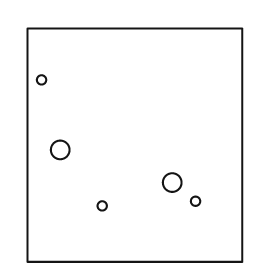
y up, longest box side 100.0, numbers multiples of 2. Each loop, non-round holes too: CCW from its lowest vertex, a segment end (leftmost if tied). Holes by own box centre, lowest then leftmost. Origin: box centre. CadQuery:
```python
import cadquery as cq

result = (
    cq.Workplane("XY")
    .moveTo(-46.0, -50.0)
    .lineTo(46.0, -50.0)
    .lineTo(46.0, 50.0)
    .lineTo(-46.0, 50.0)
    .close()
    .moveTo(-14.0, -26.0)
    .circle(2.0)
    .moveTo(26.0, -24.0)
    .circle(2.0)
    .moveTo(16.0, -16.0)
    .circle(4.0)
    .moveTo(-32.0, -2.0)
    .circle(4.0)
    .moveTo(-40.0, 28.0)
    .circle(2.0)
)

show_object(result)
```